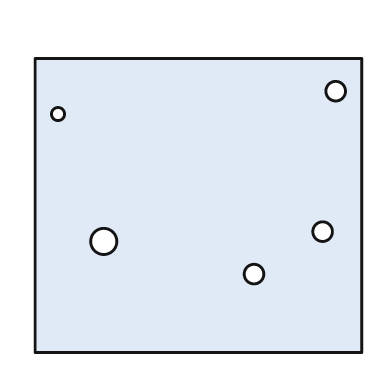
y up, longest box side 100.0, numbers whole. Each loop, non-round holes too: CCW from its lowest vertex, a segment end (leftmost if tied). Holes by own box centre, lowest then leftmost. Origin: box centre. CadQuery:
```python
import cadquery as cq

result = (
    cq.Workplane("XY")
    .moveTo(-50.0, -45.0)
    .lineTo(50.0, -45.0)
    .lineTo(50.0, 45.0)
    .lineTo(-50.0, 45.0)
    .close()
    .moveTo(17.0, -21.0)
    .circle(3.0)
    .moveTo(-29.0, -11.0)
    .circle(4.0)
    .moveTo(38.0, -8.0)
    .circle(3.0)
    .moveTo(-43.0, 28.0)
    .circle(2.0)
    .moveTo(42.0, 35.0)
    .circle(3.0)
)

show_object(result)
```